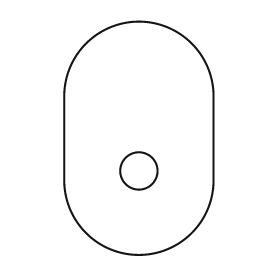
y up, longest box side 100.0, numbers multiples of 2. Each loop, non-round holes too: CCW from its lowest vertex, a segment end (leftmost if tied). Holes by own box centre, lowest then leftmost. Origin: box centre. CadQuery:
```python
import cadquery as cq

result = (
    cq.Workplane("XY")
    .moveTo(-32.0, -18.0)
    .threePointArc((0.0, -50.0), (32.0, -18.0))
    .lineTo(32.0, 18.0)
    .threePointArc((0.0, 50.0), (-32.0, 18.0))
    .close()
    .moveTo(0.0, -14.0)
    .circle(8.0)
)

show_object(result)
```